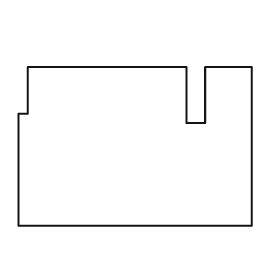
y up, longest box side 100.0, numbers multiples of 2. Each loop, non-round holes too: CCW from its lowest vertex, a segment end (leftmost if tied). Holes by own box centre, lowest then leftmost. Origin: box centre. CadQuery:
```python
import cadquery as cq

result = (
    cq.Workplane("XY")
    .moveTo(-50.0, -34.0)
    .lineTo(50.0, -34.0)
    .lineTo(50.0, 34.0)
    .lineTo(30.0, 34.0)
    .lineTo(30.0, 10.0)
    .lineTo(22.0, 10.0)
    .lineTo(22.0, 34.0)
    .lineTo(-46.0, 34.0)
    .lineTo(-46.0, 14.0)
    .lineTo(-50.0, 14.0)
    .close()
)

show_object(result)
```